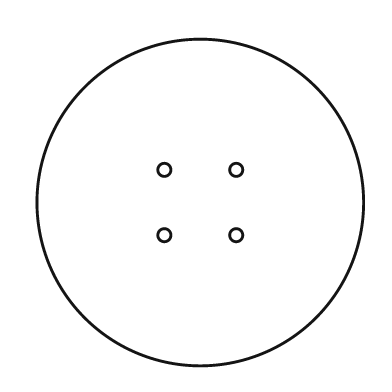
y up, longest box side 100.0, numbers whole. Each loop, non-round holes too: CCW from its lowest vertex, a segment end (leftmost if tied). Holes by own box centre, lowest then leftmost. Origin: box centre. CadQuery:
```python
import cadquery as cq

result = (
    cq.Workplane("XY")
    .moveTo(0.0, 0.0)
    .circle(50.0)
    .moveTo(-11.0, -10.0)
    .circle(2.0)
    .moveTo(11.0, -10.0)
    .circle(2.0)
    .moveTo(-11.0, 10.0)
    .circle(2.0)
    .moveTo(11.0, 10.0)
    .circle(2.0)
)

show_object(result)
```